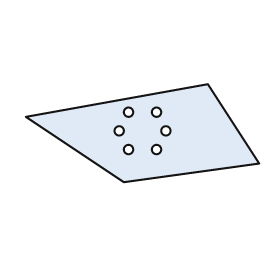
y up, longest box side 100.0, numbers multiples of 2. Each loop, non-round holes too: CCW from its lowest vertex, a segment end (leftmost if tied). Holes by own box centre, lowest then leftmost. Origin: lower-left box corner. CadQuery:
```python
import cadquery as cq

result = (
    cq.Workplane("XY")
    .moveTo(42.0, 0.0)
    .lineTo(100.0, 8.0)
    .lineTo(78.0, 42.0)
    .lineTo(0.0, 28.0)
    .close()
    .moveTo(44.0, 14.0)
    .circle(2.0)
    .moveTo(56.0, 14.0)
    .circle(2.0)
    .moveTo(40.0, 22.0)
    .circle(2.0)
    .moveTo(60.0, 22.0)
    .circle(2.0)
    .moveTo(44.0, 30.0)
    .circle(2.0)
    .moveTo(56.0, 30.0)
    .circle(2.0)
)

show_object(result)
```